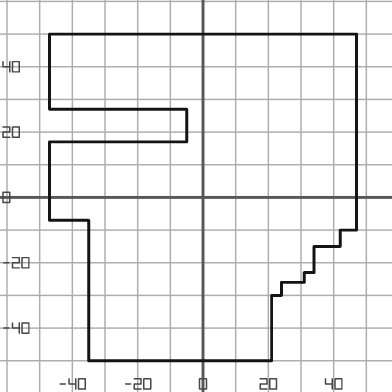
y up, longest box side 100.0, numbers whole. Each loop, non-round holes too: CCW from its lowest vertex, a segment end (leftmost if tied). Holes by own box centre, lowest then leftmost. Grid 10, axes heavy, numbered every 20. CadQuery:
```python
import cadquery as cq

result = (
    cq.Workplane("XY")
    .moveTo(-35.0, -50.0)
    .lineTo(21.0, -50.0)
    .lineTo(21.0, -30.0)
    .lineTo(24.0, -30.0)
    .lineTo(24.0, -26.0)
    .lineTo(31.0, -26.0)
    .lineTo(31.0, -23.0)
    .lineTo(34.0, -23.0)
    .lineTo(34.0, -15.0)
    .lineTo(42.0, -15.0)
    .lineTo(42.0, -10.0)
    .lineTo(47.0, -10.0)
    .lineTo(47.0, 50.0)
    .lineTo(-47.0, 50.0)
    .lineTo(-47.0, 27.0)
    .lineTo(-5.0, 27.0)
    .lineTo(-5.0, 17.0)
    .lineTo(-47.0, 17.0)
    .lineTo(-47.0, -7.0)
    .lineTo(-35.0, -7.0)
    .close()
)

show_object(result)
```